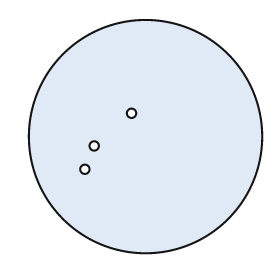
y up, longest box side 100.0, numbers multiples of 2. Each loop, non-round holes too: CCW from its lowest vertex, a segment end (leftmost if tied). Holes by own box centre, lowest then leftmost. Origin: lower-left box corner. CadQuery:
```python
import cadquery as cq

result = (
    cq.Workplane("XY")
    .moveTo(50.0, 50.0)
    .circle(50.0)
    .moveTo(24.0, 36.0)
    .circle(2.0)
    .moveTo(28.0, 46.0)
    .circle(2.0)
    .moveTo(44.0, 60.0)
    .circle(2.0)
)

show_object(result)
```